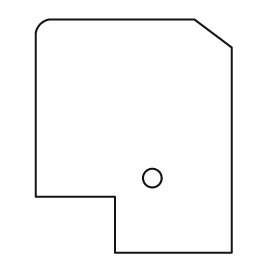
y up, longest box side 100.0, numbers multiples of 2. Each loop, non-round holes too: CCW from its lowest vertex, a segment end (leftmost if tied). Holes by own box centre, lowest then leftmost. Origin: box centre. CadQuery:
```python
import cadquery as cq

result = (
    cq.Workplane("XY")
    .moveTo(-8.0, -50.0)
    .lineTo(42.0, -50.0)
    .lineTo(42.0, 38.0)
    .lineTo(26.0, 50.0)
    .lineTo(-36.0, 50.0)
    .threePointArc((-40.0, 48.0), (-42.0, 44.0))
    .lineTo(-42.0, -26.0)
    .lineTo(-8.0, -26.0)
    .close()
    .moveTo(8.0, -18.0)
    .circle(4.0)
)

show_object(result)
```